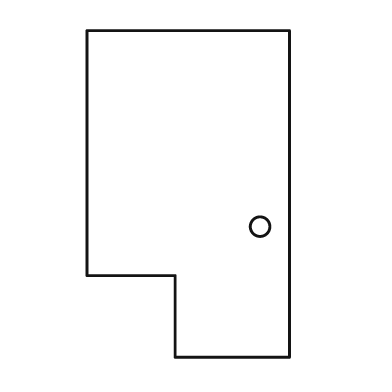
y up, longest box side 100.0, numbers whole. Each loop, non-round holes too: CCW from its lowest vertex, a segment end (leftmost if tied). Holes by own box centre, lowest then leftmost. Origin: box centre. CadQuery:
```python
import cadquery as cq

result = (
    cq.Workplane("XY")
    .moveTo(-4.0, -50.0)
    .lineTo(31.0, -50.0)
    .lineTo(31.0, 50.0)
    .lineTo(-31.0, 50.0)
    .lineTo(-31.0, -25.0)
    .lineTo(-4.0, -25.0)
    .close()
    .moveTo(22.0, -10.0)
    .circle(3.0)
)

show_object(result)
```